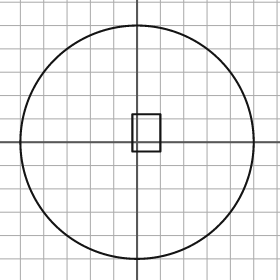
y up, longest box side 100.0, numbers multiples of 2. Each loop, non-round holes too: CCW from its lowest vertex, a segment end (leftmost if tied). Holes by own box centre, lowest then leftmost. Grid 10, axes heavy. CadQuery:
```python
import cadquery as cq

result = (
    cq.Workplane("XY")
    .moveTo(0.0, 0.0)
    .circle(50.0)
    .moveTo(-2.0, -4.0)
    .lineTo(10.0, -4.0)
    .lineTo(10.0, 12.0)
    .lineTo(-2.0, 12.0)
    .close()
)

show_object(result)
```